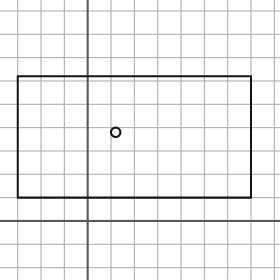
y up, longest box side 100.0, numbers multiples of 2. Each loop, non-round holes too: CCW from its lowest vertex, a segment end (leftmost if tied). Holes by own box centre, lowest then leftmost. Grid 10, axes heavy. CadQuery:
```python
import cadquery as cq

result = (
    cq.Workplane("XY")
    .moveTo(-30.0, 10.0)
    .lineTo(70.0, 10.0)
    .lineTo(70.0, 62.0)
    .lineTo(-30.0, 62.0)
    .close()
    .moveTo(12.0, 38.0)
    .circle(2.0)
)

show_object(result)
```